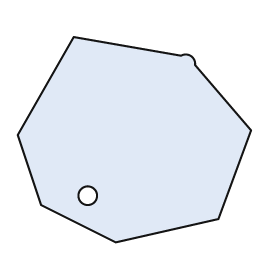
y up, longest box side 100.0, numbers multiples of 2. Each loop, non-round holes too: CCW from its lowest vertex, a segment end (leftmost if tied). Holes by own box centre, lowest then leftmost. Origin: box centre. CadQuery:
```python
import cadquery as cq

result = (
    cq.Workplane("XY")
    .moveTo(-8.0, -44.0)
    .lineTo(36.0, -34.0)
    .lineTo(50.0, 4.0)
    .lineTo(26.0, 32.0)
    .threePointArc((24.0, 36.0), (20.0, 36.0))
    .lineTo(-26.0, 44.0)
    .lineTo(-50.0, 2.0)
    .lineTo(-40.0, -28.0)
    .close()
    .moveTo(-20.0, -24.0)
    .circle(4.0)
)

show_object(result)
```